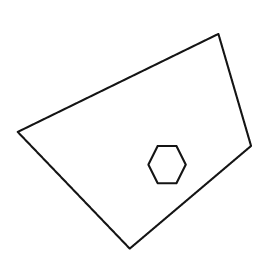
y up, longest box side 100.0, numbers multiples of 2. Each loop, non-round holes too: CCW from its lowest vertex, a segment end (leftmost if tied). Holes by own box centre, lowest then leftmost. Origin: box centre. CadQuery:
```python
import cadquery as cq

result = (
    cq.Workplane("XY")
    .moveTo(-2.0, -46.0)
    .lineTo(50.0, -2.0)
    .lineTo(36.0, 46.0)
    .lineTo(-50.0, 4.0)
    .close()
    .moveTo(10.0, -18.0)
    .lineTo(18.0, -18.0)
    .lineTo(22.0, -10.0)
    .lineTo(18.0, -2.0)
    .lineTo(10.0, -2.0)
    .lineTo(6.0, -10.0)
    .close()
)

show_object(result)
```